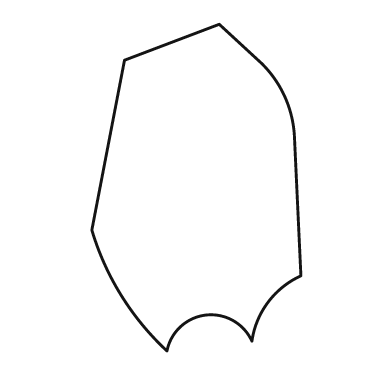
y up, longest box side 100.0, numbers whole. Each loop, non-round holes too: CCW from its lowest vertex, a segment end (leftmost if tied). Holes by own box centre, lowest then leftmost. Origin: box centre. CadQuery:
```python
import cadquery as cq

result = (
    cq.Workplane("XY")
    .moveTo(-9.0, -50.0)
    .threePointArc((3.0, -39.0), (17.0, -47.0))
    .threePointArc((22.0, -35.0), (32.0, -27.0))
    .lineTo(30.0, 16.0)
    .threePointArc((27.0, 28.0), (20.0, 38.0))
    .lineTo(7.0, 50.0)
    .lineTo(-22.0, 39.0)
    .lineTo(-32.0, -13.0)
    .threePointArc((-23.0, -33.0), (-9.0, -50.0))
    .close()
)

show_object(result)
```